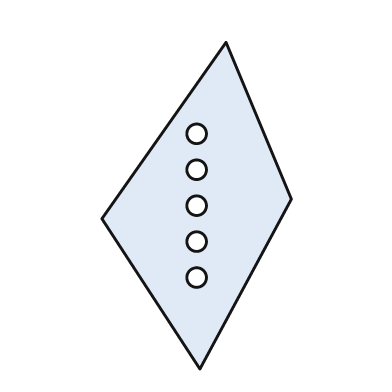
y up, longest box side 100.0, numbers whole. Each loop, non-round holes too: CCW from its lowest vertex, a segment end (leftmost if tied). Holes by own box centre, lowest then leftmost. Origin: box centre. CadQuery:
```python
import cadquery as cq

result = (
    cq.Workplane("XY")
    .moveTo(1.0, -50.0)
    .lineTo(29.0, 2.0)
    .lineTo(9.0, 50.0)
    .lineTo(-29.0, -4.0)
    .close()
    .moveTo(0.0, -22.0)
    .circle(3.0)
    .moveTo(0.0, -11.0)
    .circle(3.0)
    .moveTo(0.0, 0.0)
    .circle(3.0)
    .moveTo(0.0, 11.0)
    .circle(3.0)
    .moveTo(0.0, 22.0)
    .circle(3.0)
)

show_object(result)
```